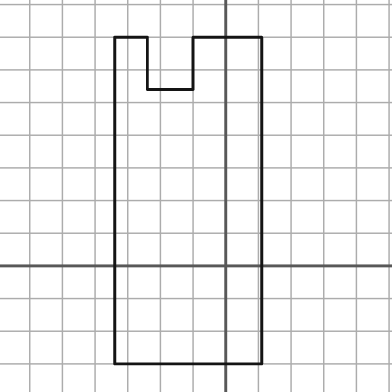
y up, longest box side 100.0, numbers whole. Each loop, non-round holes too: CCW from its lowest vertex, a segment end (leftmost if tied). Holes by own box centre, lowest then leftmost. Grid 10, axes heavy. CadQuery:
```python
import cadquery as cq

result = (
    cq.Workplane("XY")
    .moveTo(-34.0, -30.0)
    .lineTo(11.0, -30.0)
    .lineTo(11.0, 70.0)
    .lineTo(-10.0, 70.0)
    .lineTo(-10.0, 54.0)
    .lineTo(-24.0, 54.0)
    .lineTo(-24.0, 70.0)
    .lineTo(-34.0, 70.0)
    .close()
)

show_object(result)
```